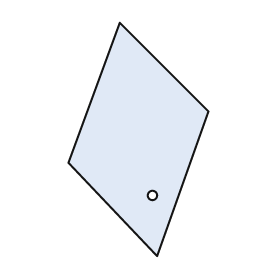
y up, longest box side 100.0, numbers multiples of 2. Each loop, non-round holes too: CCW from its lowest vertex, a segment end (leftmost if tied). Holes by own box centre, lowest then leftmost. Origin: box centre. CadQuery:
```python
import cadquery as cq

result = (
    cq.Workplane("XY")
    .moveTo(8.0, -50.0)
    .lineTo(30.0, 12.0)
    .lineTo(-8.0, 50.0)
    .lineTo(-30.0, -10.0)
    .close()
    .moveTo(6.0, -24.0)
    .circle(2.0)
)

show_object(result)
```